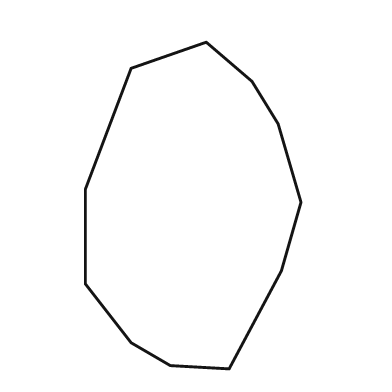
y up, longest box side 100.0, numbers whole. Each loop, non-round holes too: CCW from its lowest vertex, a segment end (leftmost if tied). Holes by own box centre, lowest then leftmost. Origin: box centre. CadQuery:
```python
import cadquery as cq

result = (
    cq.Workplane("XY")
    .moveTo(11.0, -50.0)
    .lineTo(27.0, -20.0)
    .lineTo(33.0, 1.0)
    .lineTo(26.0, 25.0)
    .lineTo(18.0, 38.0)
    .lineTo(4.0, 50.0)
    .lineTo(-19.0, 42.0)
    .lineTo(-33.0, 5.0)
    .lineTo(-33.0, -24.0)
    .lineTo(-19.0, -42.0)
    .lineTo(-7.0, -49.0)
    .close()
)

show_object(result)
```